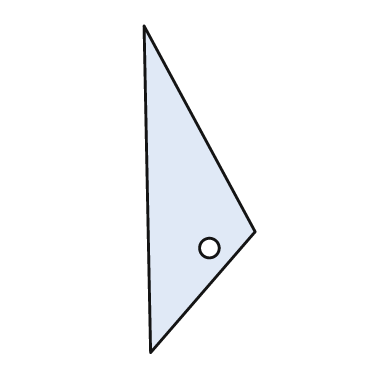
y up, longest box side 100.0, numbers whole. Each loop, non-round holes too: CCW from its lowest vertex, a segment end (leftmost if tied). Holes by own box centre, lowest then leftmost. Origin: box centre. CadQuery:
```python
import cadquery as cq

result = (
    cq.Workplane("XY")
    .moveTo(-15.0, -50.0)
    .lineTo(17.0, -13.0)
    .lineTo(-17.0, 50.0)
    .close()
    .moveTo(3.0, -18.0)
    .circle(3.0)
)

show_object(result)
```